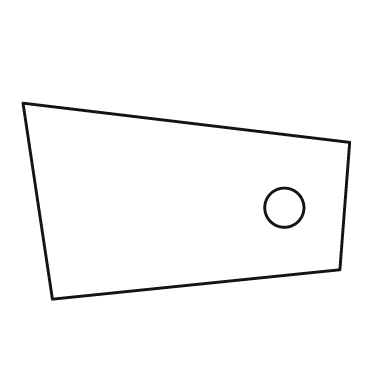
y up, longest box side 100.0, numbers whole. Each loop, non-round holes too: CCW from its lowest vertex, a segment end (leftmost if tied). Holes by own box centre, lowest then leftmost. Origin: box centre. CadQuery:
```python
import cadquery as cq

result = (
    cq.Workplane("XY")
    .moveTo(-41.0, -30.0)
    .lineTo(47.0, -21.0)
    .lineTo(50.0, 18.0)
    .lineTo(-50.0, 30.0)
    .close()
    .moveTo(30.0, -2.0)
    .circle(6.0)
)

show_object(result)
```